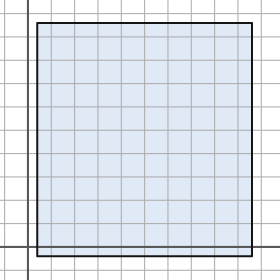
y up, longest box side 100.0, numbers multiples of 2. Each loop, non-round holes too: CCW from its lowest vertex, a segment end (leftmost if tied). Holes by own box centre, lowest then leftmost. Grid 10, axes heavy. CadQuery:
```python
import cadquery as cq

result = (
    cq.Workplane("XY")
    .moveTo(4.0, -4.0)
    .lineTo(96.0, -4.0)
    .lineTo(96.0, 96.0)
    .lineTo(4.0, 96.0)
    .close()
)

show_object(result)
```